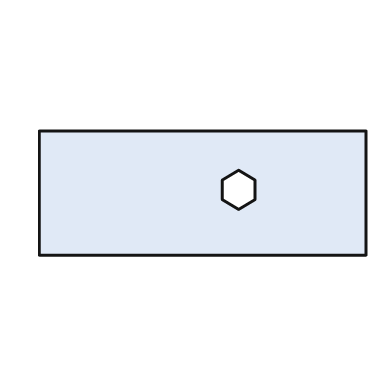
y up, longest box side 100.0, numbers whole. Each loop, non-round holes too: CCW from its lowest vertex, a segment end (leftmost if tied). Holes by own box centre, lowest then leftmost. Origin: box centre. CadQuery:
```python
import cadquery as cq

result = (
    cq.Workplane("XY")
    .moveTo(-50.0, -19.0)
    .lineTo(50.0, -19.0)
    .lineTo(50.0, 19.0)
    .lineTo(-50.0, 19.0)
    .close()
    .moveTo(11.0, -5.0)
    .lineTo(16.0, -2.0)
    .lineTo(16.0, 4.0)
    .lineTo(11.0, 7.0)
    .lineTo(6.0, 4.0)
    .lineTo(6.0, -2.0)
    .close()
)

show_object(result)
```